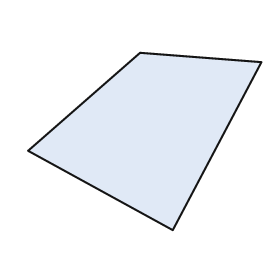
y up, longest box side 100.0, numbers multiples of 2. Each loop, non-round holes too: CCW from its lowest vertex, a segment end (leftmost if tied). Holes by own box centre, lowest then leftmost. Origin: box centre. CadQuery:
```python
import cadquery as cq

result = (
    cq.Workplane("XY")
    .moveTo(12.0, -38.0)
    .lineTo(50.0, 34.0)
    .lineTo(-2.0, 38.0)
    .lineTo(-50.0, -4.0)
    .close()
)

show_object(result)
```